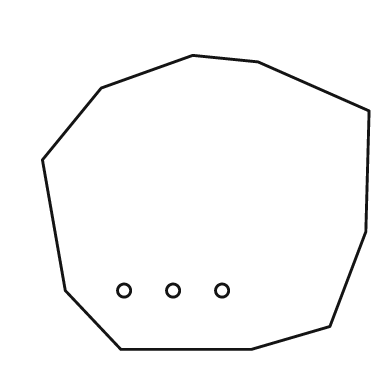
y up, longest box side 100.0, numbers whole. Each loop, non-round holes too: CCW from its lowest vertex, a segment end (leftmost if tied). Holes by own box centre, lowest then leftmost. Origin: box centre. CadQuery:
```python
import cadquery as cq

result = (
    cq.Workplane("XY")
    .moveTo(-26.0, -45.0)
    .lineTo(14.0, -45.0)
    .lineTo(38.0, -38.0)
    .lineTo(49.0, -9.0)
    .lineTo(50.0, 28.0)
    .lineTo(16.0, 43.0)
    .lineTo(-4.0, 45.0)
    .lineTo(-32.0, 35.0)
    .lineTo(-50.0, 13.0)
    .lineTo(-43.0, -27.0)
    .close()
    .moveTo(-25.0, -27.0)
    .circle(2.0)
    .moveTo(-10.0, -27.0)
    .circle(2.0)
    .moveTo(5.0, -27.0)
    .circle(2.0)
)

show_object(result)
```